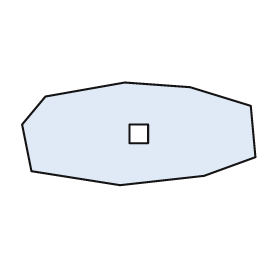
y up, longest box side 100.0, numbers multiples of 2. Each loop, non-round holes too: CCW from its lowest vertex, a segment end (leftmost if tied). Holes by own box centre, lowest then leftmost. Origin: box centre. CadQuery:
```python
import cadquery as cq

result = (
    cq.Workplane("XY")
    .moveTo(-8.0, -22.0)
    .lineTo(28.0, -18.0)
    .lineTo(50.0, -10.0)
    .lineTo(48.0, 12.0)
    .lineTo(22.0, 20.0)
    .lineTo(-6.0, 22.0)
    .lineTo(-40.0, 16.0)
    .lineTo(-50.0, 4.0)
    .lineTo(-46.0, -16.0)
    .close()
    .moveTo(-4.0, -4.0)
    .lineTo(4.0, -4.0)
    .lineTo(4.0, 4.0)
    .lineTo(-4.0, 4.0)
    .close()
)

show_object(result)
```